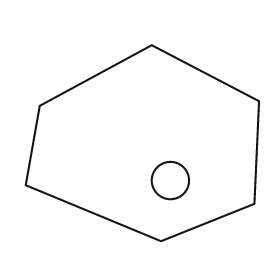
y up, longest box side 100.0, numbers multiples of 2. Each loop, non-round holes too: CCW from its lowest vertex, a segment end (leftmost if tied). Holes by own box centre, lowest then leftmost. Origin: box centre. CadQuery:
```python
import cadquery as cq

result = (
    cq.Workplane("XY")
    .moveTo(8.0, -42.0)
    .lineTo(48.0, -26.0)
    .lineTo(50.0, 18.0)
    .lineTo(4.0, 42.0)
    .lineTo(-44.0, 16.0)
    .lineTo(-50.0, -18.0)
    .close()
    .moveTo(12.0, -16.0)
    .circle(8.0)
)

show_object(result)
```